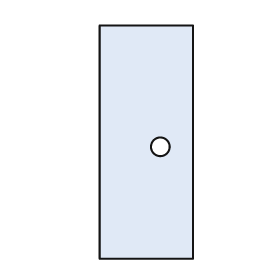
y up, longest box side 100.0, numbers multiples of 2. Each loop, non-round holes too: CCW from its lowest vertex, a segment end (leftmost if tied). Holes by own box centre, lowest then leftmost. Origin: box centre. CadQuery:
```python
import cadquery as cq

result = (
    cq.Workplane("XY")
    .moveTo(-20.0, -50.0)
    .lineTo(20.0, -50.0)
    .lineTo(20.0, 50.0)
    .lineTo(-20.0, 50.0)
    .close()
    .moveTo(6.0, -2.0)
    .circle(4.0)
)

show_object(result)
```